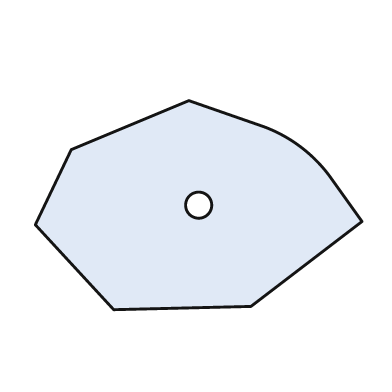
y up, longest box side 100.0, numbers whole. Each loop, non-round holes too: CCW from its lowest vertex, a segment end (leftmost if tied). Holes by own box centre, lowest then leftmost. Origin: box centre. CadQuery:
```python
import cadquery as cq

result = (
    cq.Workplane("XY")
    .moveTo(-26.0, -32.0)
    .lineTo(16.0, -31.0)
    .lineTo(50.0, -5.0)
    .lineTo(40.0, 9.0)
    .threePointArc((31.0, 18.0), (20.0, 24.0))
    .lineTo(-3.0, 32.0)
    .lineTo(-39.0, 17.0)
    .lineTo(-50.0, -6.0)
    .close()
    .moveTo(0.0, 0.0)
    .circle(4.0)
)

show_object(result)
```